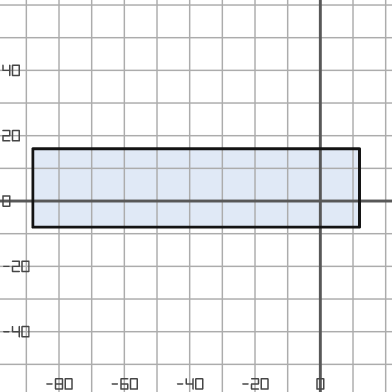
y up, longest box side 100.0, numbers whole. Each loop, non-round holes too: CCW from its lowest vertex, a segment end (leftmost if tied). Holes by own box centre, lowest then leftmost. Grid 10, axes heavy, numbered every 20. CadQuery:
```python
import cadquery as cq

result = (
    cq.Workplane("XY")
    .moveTo(-88.0, -8.0)
    .lineTo(12.0, -8.0)
    .lineTo(12.0, 16.0)
    .lineTo(-88.0, 16.0)
    .close()
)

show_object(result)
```